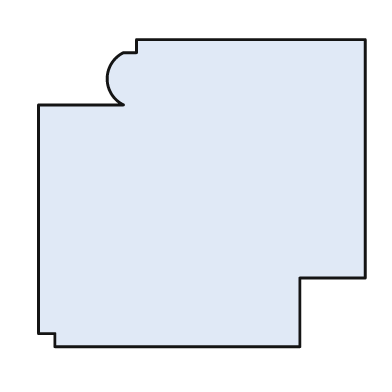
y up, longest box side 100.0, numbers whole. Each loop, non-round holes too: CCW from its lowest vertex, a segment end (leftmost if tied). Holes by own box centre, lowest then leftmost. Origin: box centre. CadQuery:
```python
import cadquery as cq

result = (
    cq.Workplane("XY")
    .moveTo(-45.0, -47.0)
    .lineTo(30.0, -47.0)
    .lineTo(30.0, -26.0)
    .lineTo(50.0, -26.0)
    .lineTo(50.0, 47.0)
    .lineTo(-20.0, 47.0)
    .lineTo(-20.0, 43.0)
    .lineTo(-24.0, 43.0)
    .threePointArc((-29.0, 35.0), (-24.0, 27.0))
    .lineTo(-50.0, 27.0)
    .lineTo(-50.0, -43.0)
    .lineTo(-45.0, -43.0)
    .close()
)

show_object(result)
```